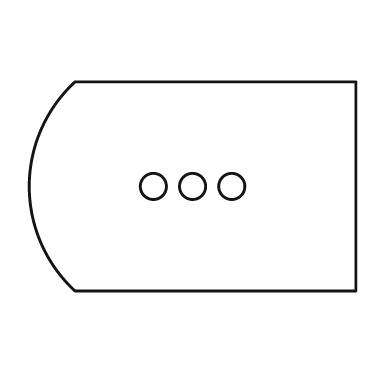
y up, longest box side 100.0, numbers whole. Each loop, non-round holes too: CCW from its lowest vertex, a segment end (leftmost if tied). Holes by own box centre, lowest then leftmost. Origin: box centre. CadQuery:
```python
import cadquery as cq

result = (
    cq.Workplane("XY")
    .moveTo(-36.0, -32.0)
    .lineTo(50.0, -32.0)
    .lineTo(50.0, 32.0)
    .lineTo(-36.0, 32.0)
    .threePointArc((-50.0, 0.0), (-36.0, -32.0))
    .close()
    .moveTo(-12.0, 0.0)
    .circle(4.0)
    .moveTo(0.0, 0.0)
    .circle(4.0)
    .moveTo(12.0, 0.0)
    .circle(4.0)
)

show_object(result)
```